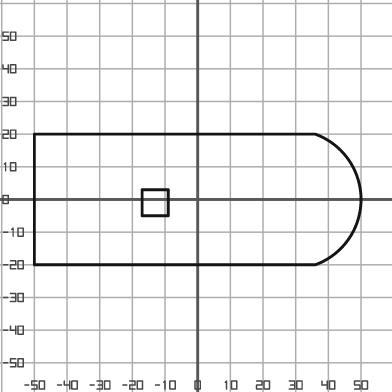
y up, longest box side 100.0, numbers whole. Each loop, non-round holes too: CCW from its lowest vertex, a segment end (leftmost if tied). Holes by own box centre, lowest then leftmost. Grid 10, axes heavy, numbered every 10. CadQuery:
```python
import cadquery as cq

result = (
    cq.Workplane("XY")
    .moveTo(-50.0, -20.0)
    .lineTo(36.0, -20.0)
    .threePointArc((50.0, 0.0), (36.0, 20.0))
    .lineTo(-50.0, 20.0)
    .close()
    .moveTo(-17.0, -5.0)
    .lineTo(-9.0, -5.0)
    .lineTo(-9.0, 3.0)
    .lineTo(-17.0, 3.0)
    .close()
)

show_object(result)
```